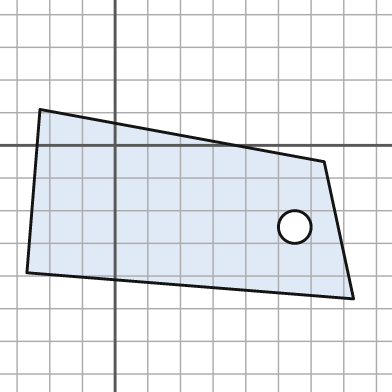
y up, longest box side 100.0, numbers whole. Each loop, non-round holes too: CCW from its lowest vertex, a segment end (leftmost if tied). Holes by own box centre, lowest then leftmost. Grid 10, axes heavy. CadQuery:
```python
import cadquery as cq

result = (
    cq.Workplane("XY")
    .moveTo(73.0, -47.0)
    .lineTo(64.0, -5.0)
    .lineTo(-23.0, 11.0)
    .lineTo(-27.0, -39.0)
    .close()
    .moveTo(55.0, -25.0)
    .circle(5.0)
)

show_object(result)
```